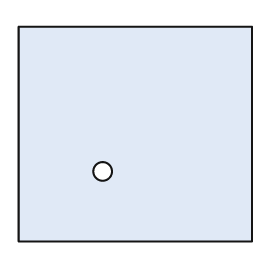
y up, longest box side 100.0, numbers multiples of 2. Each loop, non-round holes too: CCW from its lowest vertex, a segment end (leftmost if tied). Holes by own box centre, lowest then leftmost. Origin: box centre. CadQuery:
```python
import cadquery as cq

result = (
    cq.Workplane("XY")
    .moveTo(-50.0, -46.0)
    .lineTo(50.0, -46.0)
    .lineTo(50.0, 46.0)
    .lineTo(-50.0, 46.0)
    .close()
    .moveTo(-14.0, -16.0)
    .circle(4.0)
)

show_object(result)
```